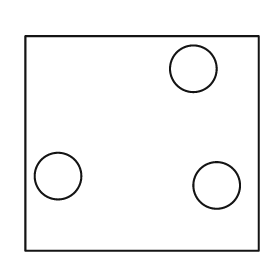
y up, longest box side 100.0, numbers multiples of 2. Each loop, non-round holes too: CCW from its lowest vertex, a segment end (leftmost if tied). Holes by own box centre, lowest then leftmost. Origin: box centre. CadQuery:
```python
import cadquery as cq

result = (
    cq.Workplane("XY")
    .moveTo(-50.0, -46.0)
    .lineTo(50.0, -46.0)
    .lineTo(50.0, 46.0)
    .lineTo(-50.0, 46.0)
    .close()
    .moveTo(32.0, -18.0)
    .circle(10.0)
    .moveTo(-36.0, -14.0)
    .circle(10.0)
    .moveTo(22.0, 32.0)
    .circle(10.0)
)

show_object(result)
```